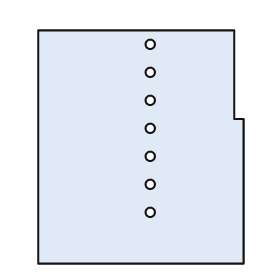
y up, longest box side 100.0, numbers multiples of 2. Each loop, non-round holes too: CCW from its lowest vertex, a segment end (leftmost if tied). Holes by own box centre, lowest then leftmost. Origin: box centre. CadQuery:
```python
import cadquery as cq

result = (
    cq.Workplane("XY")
    .moveTo(-44.0, -50.0)
    .lineTo(44.0, -50.0)
    .lineTo(44.0, 12.0)
    .lineTo(40.0, 12.0)
    .lineTo(40.0, 50.0)
    .lineTo(-44.0, 50.0)
    .close()
    .moveTo(4.0, -28.0)
    .circle(2.0)
    .moveTo(4.0, -16.0)
    .circle(2.0)
    .moveTo(4.0, -4.0)
    .circle(2.0)
    .moveTo(4.0, 8.0)
    .circle(2.0)
    .moveTo(4.0, 20.0)
    .circle(2.0)
    .moveTo(4.0, 32.0)
    .circle(2.0)
    .moveTo(4.0, 44.0)
    .circle(2.0)
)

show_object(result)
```